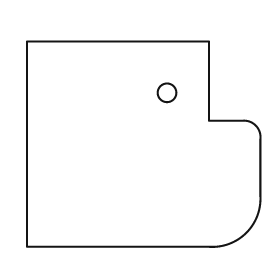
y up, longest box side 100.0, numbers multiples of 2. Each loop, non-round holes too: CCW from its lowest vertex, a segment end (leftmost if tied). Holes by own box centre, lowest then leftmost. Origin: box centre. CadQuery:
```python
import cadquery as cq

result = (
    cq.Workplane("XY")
    .moveTo(-50.0, -44.0)
    .lineTo(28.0, -44.0)
    .threePointArc((44.0, -38.0), (50.0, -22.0))
    .lineTo(50.0, 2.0)
    .threePointArc((48.0, 8.0), (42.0, 10.0))
    .lineTo(28.0, 10.0)
    .lineTo(28.0, 44.0)
    .lineTo(-50.0, 44.0)
    .close()
    .moveTo(10.0, 22.0)
    .circle(4.0)
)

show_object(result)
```